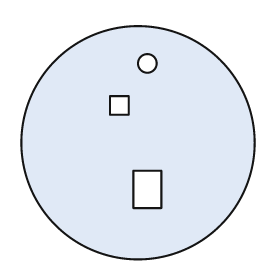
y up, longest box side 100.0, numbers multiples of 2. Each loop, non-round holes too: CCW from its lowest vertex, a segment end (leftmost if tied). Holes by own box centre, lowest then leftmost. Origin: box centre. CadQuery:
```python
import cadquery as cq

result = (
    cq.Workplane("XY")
    .moveTo(0.0, 0.0)
    .circle(50.0)
    .moveTo(-2.0, -28.0)
    .lineTo(10.0, -28.0)
    .lineTo(10.0, -12.0)
    .lineTo(-2.0, -12.0)
    .close()
    .moveTo(-12.0, 12.0)
    .lineTo(-4.0, 12.0)
    .lineTo(-4.0, 20.0)
    .lineTo(-12.0, 20.0)
    .close()
    .moveTo(4.0, 34.0)
    .circle(4.0)
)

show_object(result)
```